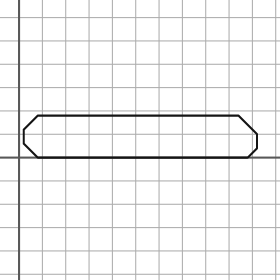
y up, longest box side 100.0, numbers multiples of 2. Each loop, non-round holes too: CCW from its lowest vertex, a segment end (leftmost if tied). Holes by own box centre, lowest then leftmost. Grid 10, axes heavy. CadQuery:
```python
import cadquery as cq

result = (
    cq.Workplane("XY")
    .moveTo(8.0, 0.0)
    .lineTo(98.0, 0.0)
    .lineTo(102.0, 4.0)
    .lineTo(102.0, 10.0)
    .lineTo(94.0, 18.0)
    .lineTo(8.0, 18.0)
    .lineTo(2.0, 12.0)
    .lineTo(2.0, 6.0)
    .close()
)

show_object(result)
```